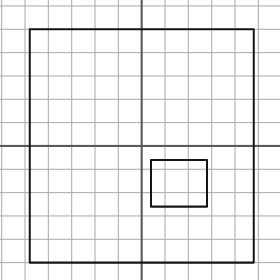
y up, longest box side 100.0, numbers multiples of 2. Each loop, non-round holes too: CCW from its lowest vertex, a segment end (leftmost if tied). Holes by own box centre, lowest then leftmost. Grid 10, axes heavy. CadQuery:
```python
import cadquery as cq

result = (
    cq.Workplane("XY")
    .moveTo(-48.0, -50.0)
    .lineTo(48.0, -50.0)
    .lineTo(48.0, 50.0)
    .lineTo(-48.0, 50.0)
    .close()
    .moveTo(4.0, -26.0)
    .lineTo(28.0, -26.0)
    .lineTo(28.0, -6.0)
    .lineTo(4.0, -6.0)
    .close()
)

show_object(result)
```